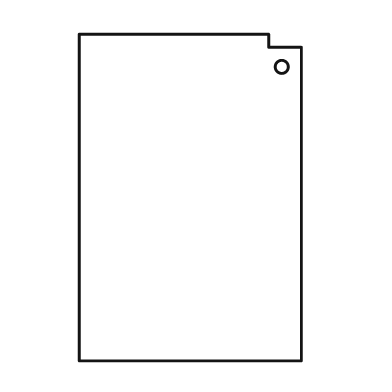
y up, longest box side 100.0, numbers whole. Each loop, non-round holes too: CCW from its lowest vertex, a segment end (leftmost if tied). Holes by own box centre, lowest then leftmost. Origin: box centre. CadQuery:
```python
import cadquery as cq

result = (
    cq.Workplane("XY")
    .moveTo(-34.0, -50.0)
    .lineTo(34.0, -50.0)
    .lineTo(34.0, 46.0)
    .lineTo(24.0, 46.0)
    .lineTo(24.0, 50.0)
    .lineTo(-34.0, 50.0)
    .close()
    .moveTo(28.0, 40.0)
    .circle(2.0)
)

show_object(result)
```